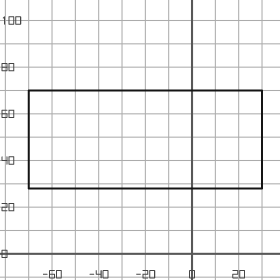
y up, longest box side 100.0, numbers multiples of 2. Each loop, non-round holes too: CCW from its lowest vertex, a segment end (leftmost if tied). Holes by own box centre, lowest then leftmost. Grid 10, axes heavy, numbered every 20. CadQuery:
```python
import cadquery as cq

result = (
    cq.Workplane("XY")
    .moveTo(-70.0, 28.0)
    .lineTo(30.0, 28.0)
    .lineTo(30.0, 70.0)
    .lineTo(-70.0, 70.0)
    .close()
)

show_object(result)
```